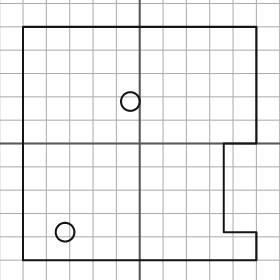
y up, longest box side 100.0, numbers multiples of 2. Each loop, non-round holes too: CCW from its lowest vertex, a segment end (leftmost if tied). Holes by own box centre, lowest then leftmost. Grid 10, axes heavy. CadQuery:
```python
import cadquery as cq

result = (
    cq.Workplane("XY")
    .moveTo(-50.0, -50.0)
    .lineTo(50.0, -50.0)
    .lineTo(50.0, -38.0)
    .lineTo(36.0, -38.0)
    .lineTo(36.0, 0.0)
    .lineTo(50.0, 0.0)
    .lineTo(50.0, 50.0)
    .lineTo(-50.0, 50.0)
    .close()
    .moveTo(-32.0, -38.0)
    .circle(4.0)
    .moveTo(-4.0, 18.0)
    .circle(4.0)
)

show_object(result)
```